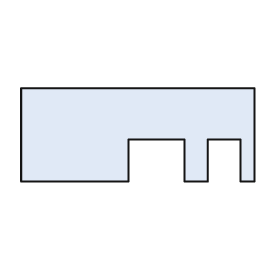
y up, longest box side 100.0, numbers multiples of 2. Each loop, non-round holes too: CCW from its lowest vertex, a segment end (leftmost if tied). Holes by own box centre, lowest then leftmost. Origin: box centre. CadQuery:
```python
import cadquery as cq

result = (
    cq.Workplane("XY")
    .moveTo(-50.0, -20.0)
    .lineTo(-4.0, -20.0)
    .lineTo(-4.0, -2.0)
    .lineTo(20.0, -2.0)
    .lineTo(20.0, -20.0)
    .lineTo(30.0, -20.0)
    .lineTo(30.0, -2.0)
    .lineTo(44.0, -2.0)
    .lineTo(44.0, -20.0)
    .lineTo(50.0, -20.0)
    .lineTo(50.0, 20.0)
    .lineTo(-50.0, 20.0)
    .close()
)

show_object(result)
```